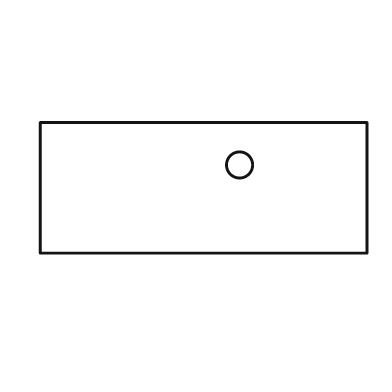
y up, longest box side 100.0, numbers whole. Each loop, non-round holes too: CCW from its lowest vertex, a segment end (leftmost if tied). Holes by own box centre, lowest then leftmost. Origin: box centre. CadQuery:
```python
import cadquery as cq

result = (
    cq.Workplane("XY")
    .moveTo(-50.0, -20.0)
    .lineTo(50.0, -20.0)
    .lineTo(50.0, 20.0)
    .lineTo(-50.0, 20.0)
    .close()
    .moveTo(11.0, 7.0)
    .circle(4.0)
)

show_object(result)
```